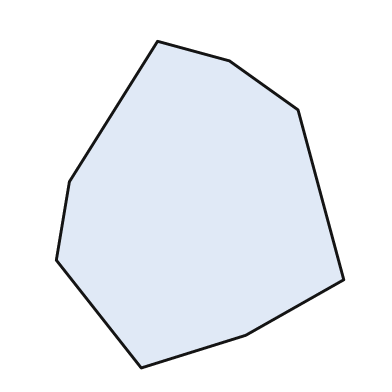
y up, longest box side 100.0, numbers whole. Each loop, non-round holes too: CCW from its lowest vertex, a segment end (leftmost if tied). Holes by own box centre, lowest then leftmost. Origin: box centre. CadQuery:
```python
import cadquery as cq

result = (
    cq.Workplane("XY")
    .moveTo(-18.0, -50.0)
    .lineTo(14.0, -40.0)
    .lineTo(44.0, -23.0)
    .lineTo(30.0, 29.0)
    .lineTo(9.0, 44.0)
    .lineTo(-13.0, 50.0)
    .lineTo(-40.0, 7.0)
    .lineTo(-44.0, -17.0)
    .close()
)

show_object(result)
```